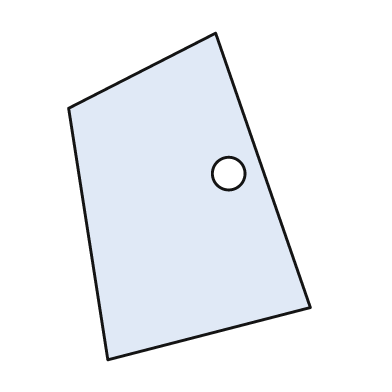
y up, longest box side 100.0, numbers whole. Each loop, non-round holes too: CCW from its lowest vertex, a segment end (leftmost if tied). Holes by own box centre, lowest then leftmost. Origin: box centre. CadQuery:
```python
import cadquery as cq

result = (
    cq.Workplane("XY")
    .moveTo(-25.0, -50.0)
    .lineTo(37.0, -34.0)
    .lineTo(8.0, 50.0)
    .lineTo(-37.0, 27.0)
    .close()
    .moveTo(12.0, 7.0)
    .circle(5.0)
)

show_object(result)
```